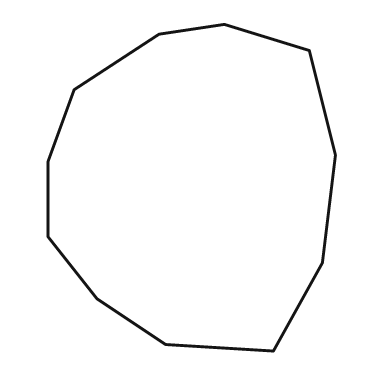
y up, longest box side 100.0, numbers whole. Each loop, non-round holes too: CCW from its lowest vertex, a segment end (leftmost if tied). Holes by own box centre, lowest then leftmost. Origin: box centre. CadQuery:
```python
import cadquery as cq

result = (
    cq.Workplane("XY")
    .moveTo(25.0, -50.0)
    .lineTo(40.0, -23.0)
    .lineTo(44.0, 10.0)
    .lineTo(36.0, 42.0)
    .lineTo(10.0, 50.0)
    .lineTo(-10.0, 47.0)
    .lineTo(-36.0, 30.0)
    .lineTo(-44.0, 8.0)
    .lineTo(-44.0, -15.0)
    .lineTo(-29.0, -34.0)
    .lineTo(-8.0, -48.0)
    .close()
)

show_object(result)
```